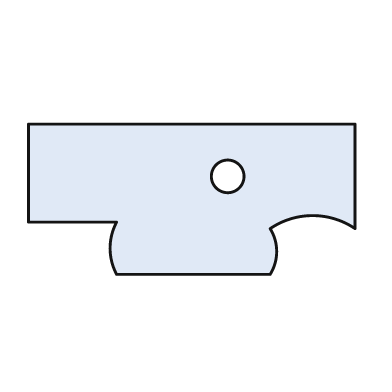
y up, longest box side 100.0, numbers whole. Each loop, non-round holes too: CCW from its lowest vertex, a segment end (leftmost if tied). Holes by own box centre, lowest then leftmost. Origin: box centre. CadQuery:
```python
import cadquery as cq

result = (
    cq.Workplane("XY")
    .moveTo(-23.0, -23.0)
    .lineTo(24.0, -23.0)
    .threePointArc((26.0, -16.0), (24.0, -9.0))
    .threePointArc((37.0, -5.0), (50.0, -9.0))
    .lineTo(50.0, 23.0)
    .lineTo(-50.0, 23.0)
    .lineTo(-50.0, -7.0)
    .lineTo(-23.0, -7.0)
    .threePointArc((-25.0, -15.0), (-23.0, -23.0))
    .close()
    .moveTo(11.0, 7.0)
    .circle(5.0)
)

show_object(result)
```